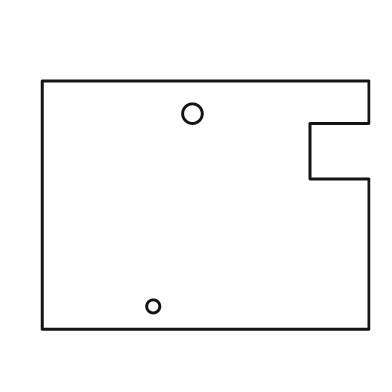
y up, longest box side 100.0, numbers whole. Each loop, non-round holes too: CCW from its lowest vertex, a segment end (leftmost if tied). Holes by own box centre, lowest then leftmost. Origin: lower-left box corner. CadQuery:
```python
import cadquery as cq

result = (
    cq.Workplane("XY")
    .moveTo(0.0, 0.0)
    .lineTo(100.0, 0.0)
    .lineTo(100.0, 46.0)
    .lineTo(82.0, 46.0)
    .lineTo(82.0, 63.0)
    .lineTo(100.0, 63.0)
    .lineTo(100.0, 76.0)
    .lineTo(0.0, 76.0)
    .close()
    .moveTo(34.0, 7.0)
    .circle(2.0)
    .moveTo(46.0, 66.0)
    .circle(3.0)
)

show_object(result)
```